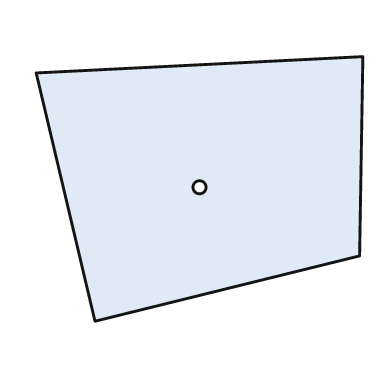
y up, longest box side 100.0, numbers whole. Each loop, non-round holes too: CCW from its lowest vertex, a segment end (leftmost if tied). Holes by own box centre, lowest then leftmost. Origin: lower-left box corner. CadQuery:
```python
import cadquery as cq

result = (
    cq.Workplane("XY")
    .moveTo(18.0, 0.0)
    .lineTo(99.0, 20.0)
    .lineTo(100.0, 81.0)
    .lineTo(0.0, 76.0)
    .close()
    .moveTo(50.0, 41.0)
    .circle(2.0)
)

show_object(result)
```